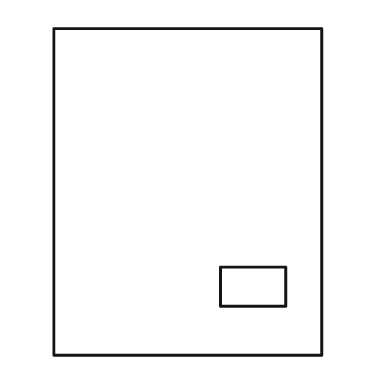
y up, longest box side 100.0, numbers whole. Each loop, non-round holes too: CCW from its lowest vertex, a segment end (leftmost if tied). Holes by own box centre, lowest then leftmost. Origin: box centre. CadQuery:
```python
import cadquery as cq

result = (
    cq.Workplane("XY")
    .moveTo(-41.0, -50.0)
    .lineTo(41.0, -50.0)
    .lineTo(41.0, 50.0)
    .lineTo(-41.0, 50.0)
    .close()
    .moveTo(10.0, -35.0)
    .lineTo(30.0, -35.0)
    .lineTo(30.0, -23.0)
    .lineTo(10.0, -23.0)
    .close()
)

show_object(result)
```